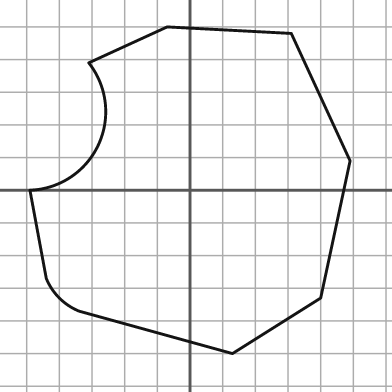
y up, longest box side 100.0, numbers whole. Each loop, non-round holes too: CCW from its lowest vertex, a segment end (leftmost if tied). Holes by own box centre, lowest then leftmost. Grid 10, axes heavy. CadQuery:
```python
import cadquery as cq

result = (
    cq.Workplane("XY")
    .moveTo(13.0, -50.0)
    .lineTo(40.0, -33.0)
    .lineTo(49.0, 9.0)
    .lineTo(31.0, 48.0)
    .lineTo(-7.0, 50.0)
    .lineTo(-31.0, 39.0)
    .threePointArc((-28.0, 14.0), (-49.0, 0.0))
    .lineTo(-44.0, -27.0)
    .threePointArc((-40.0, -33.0), (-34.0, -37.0))
    .close()
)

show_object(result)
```